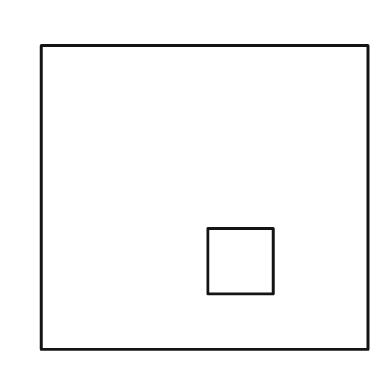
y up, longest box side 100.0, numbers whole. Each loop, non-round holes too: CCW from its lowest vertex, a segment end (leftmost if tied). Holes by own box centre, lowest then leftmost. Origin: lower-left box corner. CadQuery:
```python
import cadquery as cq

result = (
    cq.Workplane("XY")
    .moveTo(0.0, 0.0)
    .lineTo(100.0, 0.0)
    .lineTo(100.0, 93.0)
    .lineTo(0.0, 93.0)
    .close()
    .moveTo(51.0, 17.0)
    .lineTo(71.0, 17.0)
    .lineTo(71.0, 37.0)
    .lineTo(51.0, 37.0)
    .close()
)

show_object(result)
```